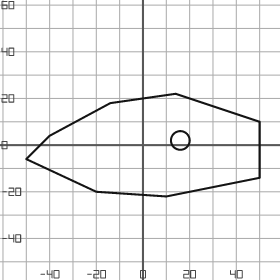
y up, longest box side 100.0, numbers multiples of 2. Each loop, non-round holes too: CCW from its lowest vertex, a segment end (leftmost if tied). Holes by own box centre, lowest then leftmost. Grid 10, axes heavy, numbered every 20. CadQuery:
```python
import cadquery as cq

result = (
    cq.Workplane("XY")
    .moveTo(10.0, -22.0)
    .lineTo(50.0, -14.0)
    .lineTo(50.0, 10.0)
    .lineTo(14.0, 22.0)
    .lineTo(-14.0, 18.0)
    .lineTo(-40.0, 4.0)
    .lineTo(-50.0, -6.0)
    .lineTo(-20.0, -20.0)
    .close()
    .moveTo(16.0, 2.0)
    .circle(4.0)
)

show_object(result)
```